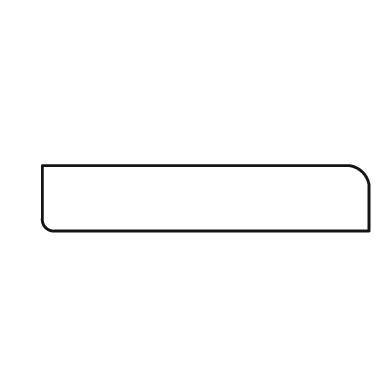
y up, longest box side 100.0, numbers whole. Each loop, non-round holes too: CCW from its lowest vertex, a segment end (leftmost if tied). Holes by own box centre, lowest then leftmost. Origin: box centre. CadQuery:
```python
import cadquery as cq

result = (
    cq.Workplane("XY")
    .moveTo(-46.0, -10.0)
    .lineTo(50.0, -10.0)
    .lineTo(50.0, 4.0)
    .threePointArc((48.0, 8.0), (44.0, 10.0))
    .lineTo(-50.0, 10.0)
    .lineTo(-50.0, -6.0)
    .threePointArc((-49.0, -9.0), (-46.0, -10.0))
    .close()
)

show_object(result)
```